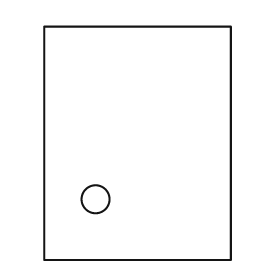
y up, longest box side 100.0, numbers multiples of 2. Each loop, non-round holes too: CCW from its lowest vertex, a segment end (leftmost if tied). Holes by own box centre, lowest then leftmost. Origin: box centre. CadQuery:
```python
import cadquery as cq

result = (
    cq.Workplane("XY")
    .moveTo(-40.0, -50.0)
    .lineTo(40.0, -50.0)
    .lineTo(40.0, 50.0)
    .lineTo(-40.0, 50.0)
    .close()
    .moveTo(-18.0, -24.0)
    .circle(6.0)
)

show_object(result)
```